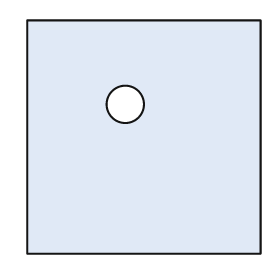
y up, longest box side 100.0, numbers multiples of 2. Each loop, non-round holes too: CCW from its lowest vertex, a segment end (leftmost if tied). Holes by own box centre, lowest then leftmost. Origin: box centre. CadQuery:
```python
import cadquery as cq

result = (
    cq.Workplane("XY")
    .moveTo(-50.0, -50.0)
    .lineTo(50.0, -50.0)
    .lineTo(50.0, 50.0)
    .lineTo(-50.0, 50.0)
    .close()
    .moveTo(-8.0, 14.0)
    .circle(8.0)
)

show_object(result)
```